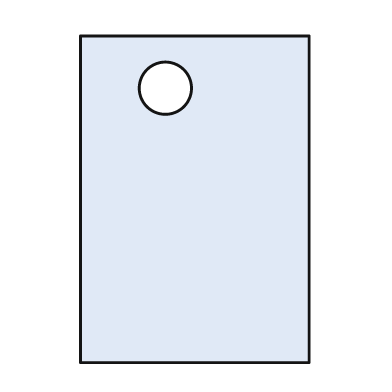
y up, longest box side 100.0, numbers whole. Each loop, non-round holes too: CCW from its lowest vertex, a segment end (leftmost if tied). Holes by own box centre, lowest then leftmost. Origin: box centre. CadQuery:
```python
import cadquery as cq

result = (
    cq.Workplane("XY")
    .moveTo(-35.0, -50.0)
    .lineTo(35.0, -50.0)
    .lineTo(35.0, 50.0)
    .lineTo(-35.0, 50.0)
    .close()
    .moveTo(-9.0, 34.0)
    .circle(8.0)
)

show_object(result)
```